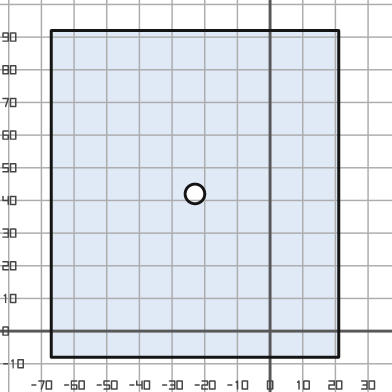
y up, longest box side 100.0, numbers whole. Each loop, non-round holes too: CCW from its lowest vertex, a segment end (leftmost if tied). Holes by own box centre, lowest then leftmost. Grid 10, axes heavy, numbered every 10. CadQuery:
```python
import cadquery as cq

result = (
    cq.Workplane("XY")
    .moveTo(-67.0, -8.0)
    .lineTo(21.0, -8.0)
    .lineTo(21.0, 92.0)
    .lineTo(-67.0, 92.0)
    .close()
    .moveTo(-23.0, 42.0)
    .circle(3.0)
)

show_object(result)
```